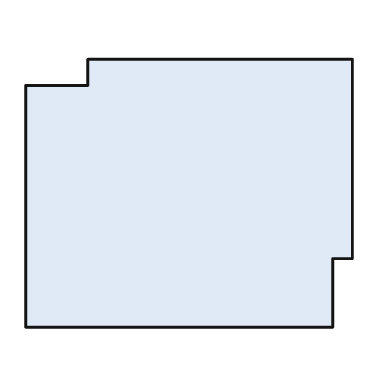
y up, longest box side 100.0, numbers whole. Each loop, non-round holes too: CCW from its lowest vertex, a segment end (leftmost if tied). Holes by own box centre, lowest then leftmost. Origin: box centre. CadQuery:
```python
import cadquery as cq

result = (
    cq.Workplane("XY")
    .moveTo(-50.0, -41.0)
    .lineTo(44.0, -41.0)
    .lineTo(44.0, -20.0)
    .lineTo(50.0, -20.0)
    .lineTo(50.0, 41.0)
    .lineTo(-31.0, 41.0)
    .lineTo(-31.0, 33.0)
    .lineTo(-50.0, 33.0)
    .close()
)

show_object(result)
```